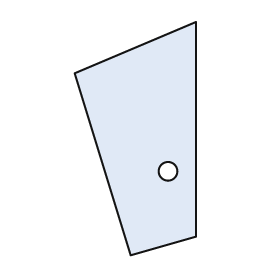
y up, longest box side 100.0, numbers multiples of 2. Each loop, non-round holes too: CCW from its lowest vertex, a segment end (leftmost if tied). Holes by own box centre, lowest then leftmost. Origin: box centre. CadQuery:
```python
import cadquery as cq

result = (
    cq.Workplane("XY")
    .moveTo(-2.0, -50.0)
    .lineTo(26.0, -42.0)
    .lineTo(26.0, 50.0)
    .lineTo(-26.0, 28.0)
    .close()
    .moveTo(14.0, -14.0)
    .circle(4.0)
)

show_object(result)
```